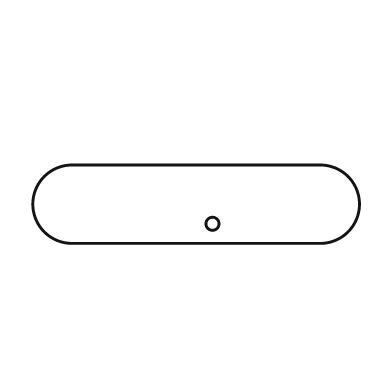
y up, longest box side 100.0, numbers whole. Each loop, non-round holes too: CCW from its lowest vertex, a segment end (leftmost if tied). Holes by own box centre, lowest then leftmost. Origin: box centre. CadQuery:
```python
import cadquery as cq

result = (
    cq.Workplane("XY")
    .moveTo(-38.0, -12.0)
    .lineTo(38.0, -12.0)
    .threePointArc((50.0, 0.0), (38.0, 12.0))
    .lineTo(-38.0, 12.0)
    .threePointArc((-50.0, 0.0), (-38.0, -12.0))
    .close()
    .moveTo(5.0, -6.0)
    .circle(2.0)
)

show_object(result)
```